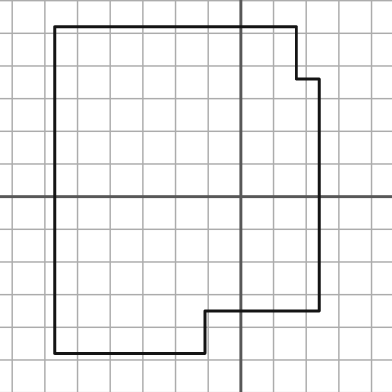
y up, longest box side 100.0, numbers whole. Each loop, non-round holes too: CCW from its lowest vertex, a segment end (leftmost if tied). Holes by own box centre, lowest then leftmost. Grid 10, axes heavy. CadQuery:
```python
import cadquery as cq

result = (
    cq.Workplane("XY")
    .moveTo(-57.0, -48.0)
    .lineTo(-11.0, -48.0)
    .lineTo(-11.0, -35.0)
    .lineTo(24.0, -35.0)
    .lineTo(24.0, 36.0)
    .lineTo(17.0, 36.0)
    .lineTo(17.0, 52.0)
    .lineTo(-57.0, 52.0)
    .close()
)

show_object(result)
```